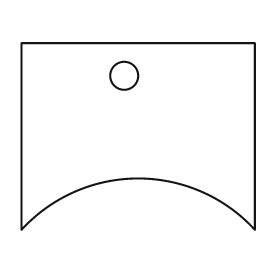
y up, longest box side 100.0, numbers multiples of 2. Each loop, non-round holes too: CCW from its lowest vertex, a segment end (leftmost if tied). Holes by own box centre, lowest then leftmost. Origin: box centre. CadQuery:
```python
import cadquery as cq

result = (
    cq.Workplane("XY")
    .moveTo(-50.0, -40.0)
    .threePointArc((0.0, -18.0), (50.0, -40.0))
    .lineTo(50.0, 40.0)
    .lineTo(-50.0, 40.0)
    .close()
    .moveTo(-6.0, 26.0)
    .circle(6.0)
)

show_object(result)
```